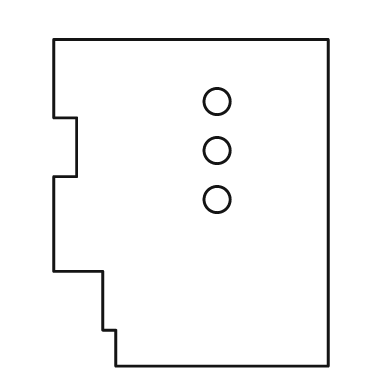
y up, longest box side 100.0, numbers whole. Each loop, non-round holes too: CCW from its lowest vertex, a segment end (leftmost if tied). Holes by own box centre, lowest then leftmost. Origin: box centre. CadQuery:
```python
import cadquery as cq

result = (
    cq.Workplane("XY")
    .moveTo(-23.0, -50.0)
    .lineTo(42.0, -50.0)
    .lineTo(42.0, 50.0)
    .lineTo(-42.0, 50.0)
    .lineTo(-42.0, 26.0)
    .lineTo(-35.0, 26.0)
    .lineTo(-35.0, 8.0)
    .lineTo(-42.0, 8.0)
    .lineTo(-42.0, -21.0)
    .lineTo(-27.0, -21.0)
    .lineTo(-27.0, -39.0)
    .lineTo(-23.0, -39.0)
    .close()
    .moveTo(8.0, 1.0)
    .circle(4.0)
    .moveTo(8.0, 16.0)
    .circle(4.0)
    .moveTo(8.0, 31.0)
    .circle(4.0)
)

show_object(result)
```